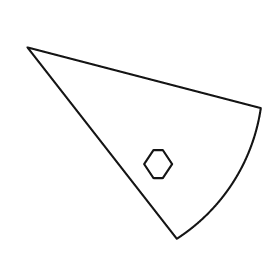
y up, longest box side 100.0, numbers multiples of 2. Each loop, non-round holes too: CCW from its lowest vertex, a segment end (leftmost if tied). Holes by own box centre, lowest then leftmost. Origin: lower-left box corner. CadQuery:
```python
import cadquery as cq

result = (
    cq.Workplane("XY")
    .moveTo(64.0, 0.0)
    .threePointArc((88.0, 24.0), (100.0, 56.0))
    .lineTo(0.0, 82.0)
    .close()
    .moveTo(54.0, 26.0)
    .lineTo(58.0, 26.0)
    .lineTo(62.0, 32.0)
    .lineTo(58.0, 38.0)
    .lineTo(54.0, 38.0)
    .lineTo(50.0, 32.0)
    .close()
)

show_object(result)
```